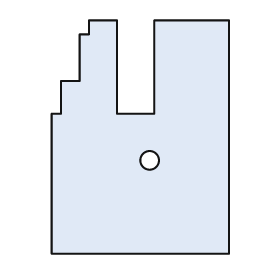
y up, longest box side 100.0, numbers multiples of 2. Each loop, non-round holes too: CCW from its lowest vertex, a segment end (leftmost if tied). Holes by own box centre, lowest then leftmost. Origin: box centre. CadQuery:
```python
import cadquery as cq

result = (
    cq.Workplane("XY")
    .moveTo(-38.0, -50.0)
    .lineTo(38.0, -50.0)
    .lineTo(38.0, 50.0)
    .lineTo(6.0, 50.0)
    .lineTo(6.0, 10.0)
    .lineTo(-10.0, 10.0)
    .lineTo(-10.0, 50.0)
    .lineTo(-22.0, 50.0)
    .lineTo(-22.0, 44.0)
    .lineTo(-26.0, 44.0)
    .lineTo(-26.0, 24.0)
    .lineTo(-34.0, 24.0)
    .lineTo(-34.0, 10.0)
    .lineTo(-38.0, 10.0)
    .close()
    .moveTo(4.0, -10.0)
    .circle(4.0)
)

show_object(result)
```